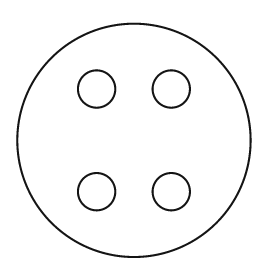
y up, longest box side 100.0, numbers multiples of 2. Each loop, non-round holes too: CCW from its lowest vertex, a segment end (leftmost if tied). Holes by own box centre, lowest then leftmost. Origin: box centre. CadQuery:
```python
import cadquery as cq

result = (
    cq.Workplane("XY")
    .moveTo(0.0, 0.0)
    .circle(50.0)
    .moveTo(-16.0, -22.0)
    .circle(8.0)
    .moveTo(16.0, -22.0)
    .circle(8.0)
    .moveTo(-16.0, 22.0)
    .circle(8.0)
    .moveTo(16.0, 22.0)
    .circle(8.0)
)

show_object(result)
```